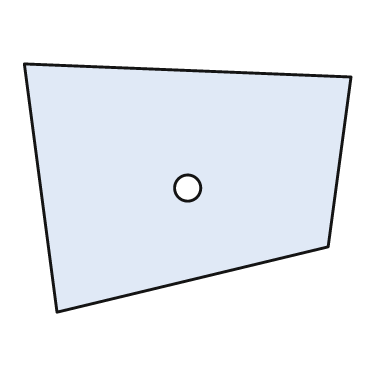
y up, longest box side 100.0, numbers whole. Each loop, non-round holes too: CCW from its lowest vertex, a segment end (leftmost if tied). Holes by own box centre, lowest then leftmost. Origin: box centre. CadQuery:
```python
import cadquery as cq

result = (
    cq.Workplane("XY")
    .moveTo(-40.0, -38.0)
    .lineTo(43.0, -18.0)
    .lineTo(50.0, 34.0)
    .lineTo(-50.0, 38.0)
    .close()
    .moveTo(0.0, 0.0)
    .circle(4.0)
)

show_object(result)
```